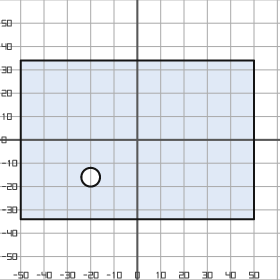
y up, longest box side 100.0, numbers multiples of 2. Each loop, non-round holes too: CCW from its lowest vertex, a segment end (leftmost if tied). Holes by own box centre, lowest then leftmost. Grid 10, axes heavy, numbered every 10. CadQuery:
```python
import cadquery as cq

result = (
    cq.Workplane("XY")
    .moveTo(-50.0, -34.0)
    .lineTo(50.0, -34.0)
    .lineTo(50.0, 34.0)
    .lineTo(-50.0, 34.0)
    .close()
    .moveTo(-20.0, -16.0)
    .circle(4.0)
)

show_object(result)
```